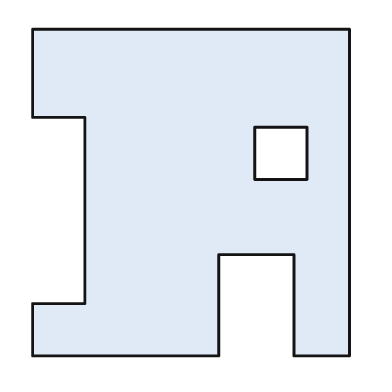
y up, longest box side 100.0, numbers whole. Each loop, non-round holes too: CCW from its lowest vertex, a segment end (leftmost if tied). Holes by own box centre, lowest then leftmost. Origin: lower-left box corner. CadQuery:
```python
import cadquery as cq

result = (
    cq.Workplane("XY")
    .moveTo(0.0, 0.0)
    .lineTo(57.0, 0.0)
    .lineTo(57.0, 31.0)
    .lineTo(80.0, 31.0)
    .lineTo(80.0, 0.0)
    .lineTo(97.0, 0.0)
    .lineTo(97.0, 100.0)
    .lineTo(0.0, 100.0)
    .lineTo(0.0, 73.0)
    .lineTo(16.0, 73.0)
    .lineTo(16.0, 16.0)
    .lineTo(0.0, 16.0)
    .close()
    .moveTo(68.0, 54.0)
    .lineTo(84.0, 54.0)
    .lineTo(84.0, 70.0)
    .lineTo(68.0, 70.0)
    .close()
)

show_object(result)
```